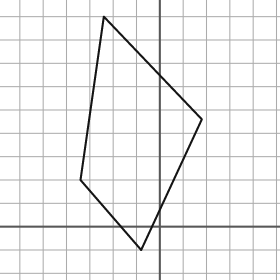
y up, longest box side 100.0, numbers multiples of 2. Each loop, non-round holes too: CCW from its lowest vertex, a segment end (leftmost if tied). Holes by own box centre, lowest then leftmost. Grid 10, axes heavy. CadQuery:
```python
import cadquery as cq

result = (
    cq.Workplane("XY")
    .moveTo(-8.0, -10.0)
    .lineTo(18.0, 46.0)
    .lineTo(-24.0, 90.0)
    .lineTo(-34.0, 20.0)
    .close()
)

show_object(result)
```